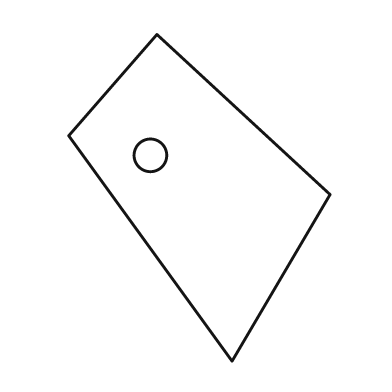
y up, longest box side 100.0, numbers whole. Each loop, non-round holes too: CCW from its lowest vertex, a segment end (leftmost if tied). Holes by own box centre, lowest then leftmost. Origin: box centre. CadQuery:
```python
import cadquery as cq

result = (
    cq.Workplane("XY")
    .moveTo(10.0, -50.0)
    .lineTo(40.0, 1.0)
    .lineTo(-13.0, 50.0)
    .lineTo(-40.0, 19.0)
    .close()
    .moveTo(-15.0, 13.0)
    .circle(5.0)
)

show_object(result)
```